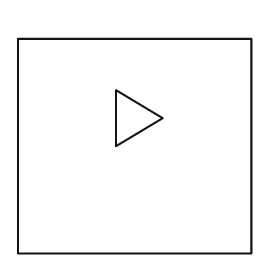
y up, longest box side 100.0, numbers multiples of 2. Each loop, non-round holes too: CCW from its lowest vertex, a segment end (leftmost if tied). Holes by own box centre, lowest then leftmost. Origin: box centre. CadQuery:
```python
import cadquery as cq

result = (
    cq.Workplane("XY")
    .moveTo(-50.0, -46.0)
    .lineTo(50.0, -46.0)
    .lineTo(50.0, 46.0)
    .lineTo(-50.0, 46.0)
    .close()
    .moveTo(-8.0, 0.0)
    .lineTo(12.0, 12.0)
    .lineTo(-8.0, 24.0)
    .close()
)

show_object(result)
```